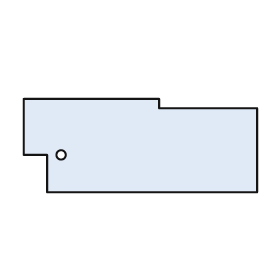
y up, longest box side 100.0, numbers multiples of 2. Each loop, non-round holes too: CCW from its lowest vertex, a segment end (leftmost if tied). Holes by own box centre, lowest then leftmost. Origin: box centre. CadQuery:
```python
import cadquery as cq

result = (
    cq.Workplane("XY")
    .moveTo(-40.0, -20.0)
    .lineTo(50.0, -20.0)
    .lineTo(50.0, 16.0)
    .lineTo(8.0, 16.0)
    .lineTo(8.0, 20.0)
    .lineTo(-50.0, 20.0)
    .lineTo(-50.0, -4.0)
    .lineTo(-40.0, -4.0)
    .close()
    .moveTo(-34.0, -4.0)
    .circle(2.0)
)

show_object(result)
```